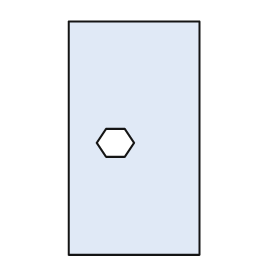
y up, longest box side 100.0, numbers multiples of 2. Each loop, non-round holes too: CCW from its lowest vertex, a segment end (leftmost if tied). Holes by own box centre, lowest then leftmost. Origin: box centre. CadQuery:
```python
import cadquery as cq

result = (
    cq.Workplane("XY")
    .moveTo(-28.0, -50.0)
    .lineTo(28.0, -50.0)
    .lineTo(28.0, 50.0)
    .lineTo(-28.0, 50.0)
    .close()
    .moveTo(-12.0, -8.0)
    .lineTo(-4.0, -8.0)
    .lineTo(0.0, -2.0)
    .lineTo(-4.0, 4.0)
    .lineTo(-12.0, 4.0)
    .lineTo(-16.0, -2.0)
    .close()
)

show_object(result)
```